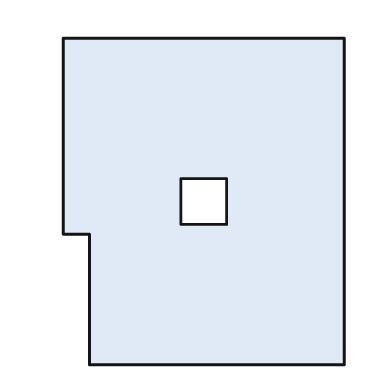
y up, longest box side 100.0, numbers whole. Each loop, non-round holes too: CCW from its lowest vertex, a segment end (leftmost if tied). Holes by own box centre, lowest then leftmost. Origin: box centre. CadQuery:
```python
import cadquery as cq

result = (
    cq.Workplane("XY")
    .moveTo(-35.0, -50.0)
    .lineTo(43.0, -50.0)
    .lineTo(43.0, 50.0)
    .lineTo(-43.0, 50.0)
    .lineTo(-43.0, -10.0)
    .lineTo(-35.0, -10.0)
    .close()
    .moveTo(-7.0, -7.0)
    .lineTo(7.0, -7.0)
    .lineTo(7.0, 7.0)
    .lineTo(-7.0, 7.0)
    .close()
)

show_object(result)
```